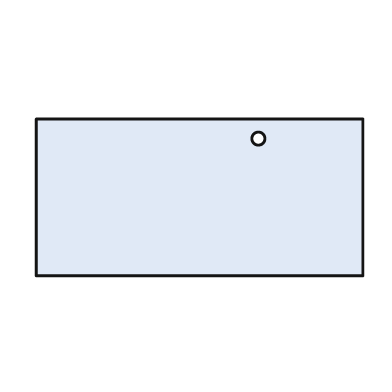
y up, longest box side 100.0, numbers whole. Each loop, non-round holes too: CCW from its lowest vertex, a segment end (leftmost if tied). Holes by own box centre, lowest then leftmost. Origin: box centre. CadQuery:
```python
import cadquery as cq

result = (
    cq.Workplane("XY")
    .moveTo(-50.0, -24.0)
    .lineTo(50.0, -24.0)
    .lineTo(50.0, 24.0)
    .lineTo(-50.0, 24.0)
    .close()
    .moveTo(18.0, 18.0)
    .circle(2.0)
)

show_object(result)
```